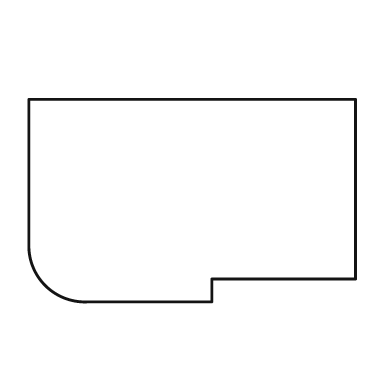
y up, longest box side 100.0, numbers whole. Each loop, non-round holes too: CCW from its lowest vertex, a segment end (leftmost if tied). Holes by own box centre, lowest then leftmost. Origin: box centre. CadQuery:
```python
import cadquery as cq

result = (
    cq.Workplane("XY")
    .moveTo(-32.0, -31.0)
    .lineTo(6.0, -31.0)
    .lineTo(6.0, -24.0)
    .lineTo(50.0, -24.0)
    .lineTo(50.0, 31.0)
    .lineTo(-50.0, 31.0)
    .lineTo(-50.0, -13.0)
    .threePointArc((-45.0, -26.0), (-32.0, -31.0))
    .close()
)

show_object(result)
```